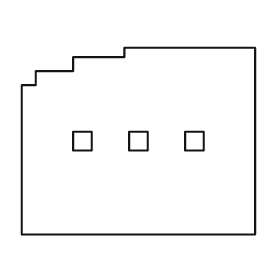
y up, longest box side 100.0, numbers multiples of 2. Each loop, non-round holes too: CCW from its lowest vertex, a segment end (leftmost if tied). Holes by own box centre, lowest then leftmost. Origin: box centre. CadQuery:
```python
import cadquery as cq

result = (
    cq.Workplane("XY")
    .moveTo(-50.0, -40.0)
    .lineTo(50.0, -40.0)
    .lineTo(50.0, 40.0)
    .lineTo(-6.0, 40.0)
    .lineTo(-6.0, 36.0)
    .lineTo(-28.0, 36.0)
    .lineTo(-28.0, 30.0)
    .lineTo(-44.0, 30.0)
    .lineTo(-44.0, 24.0)
    .lineTo(-50.0, 24.0)
    .close()
    .moveTo(-28.0, -4.0)
    .lineTo(-20.0, -4.0)
    .lineTo(-20.0, 4.0)
    .lineTo(-28.0, 4.0)
    .close()
    .moveTo(-4.0, -4.0)
    .lineTo(4.0, -4.0)
    .lineTo(4.0, 4.0)
    .lineTo(-4.0, 4.0)
    .close()
    .moveTo(20.0, -4.0)
    .lineTo(28.0, -4.0)
    .lineTo(28.0, 4.0)
    .lineTo(20.0, 4.0)
    .close()
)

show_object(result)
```